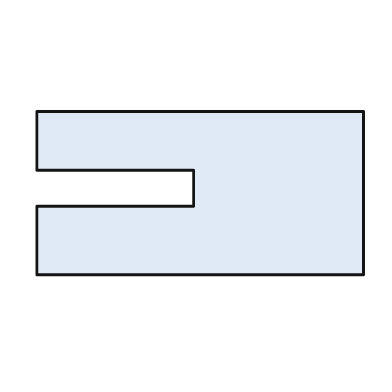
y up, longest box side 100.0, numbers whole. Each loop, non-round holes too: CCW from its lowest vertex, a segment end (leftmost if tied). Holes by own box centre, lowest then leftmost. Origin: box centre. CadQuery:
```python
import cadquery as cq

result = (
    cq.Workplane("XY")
    .moveTo(-50.0, -25.0)
    .lineTo(50.0, -25.0)
    .lineTo(50.0, 25.0)
    .lineTo(-50.0, 25.0)
    .lineTo(-50.0, 7.0)
    .lineTo(-2.0, 7.0)
    .lineTo(-2.0, -4.0)
    .lineTo(-50.0, -4.0)
    .close()
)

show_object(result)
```